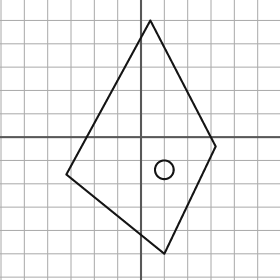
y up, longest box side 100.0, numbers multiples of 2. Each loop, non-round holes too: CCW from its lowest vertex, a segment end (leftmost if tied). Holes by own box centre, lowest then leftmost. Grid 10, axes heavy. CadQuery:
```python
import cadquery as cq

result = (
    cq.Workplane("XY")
    .moveTo(10.0, -50.0)
    .lineTo(32.0, -4.0)
    .lineTo(4.0, 50.0)
    .lineTo(-32.0, -16.0)
    .close()
    .moveTo(10.0, -14.0)
    .circle(4.0)
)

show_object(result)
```